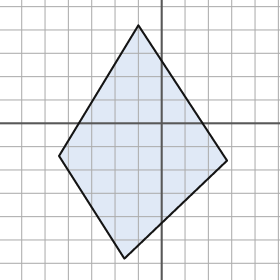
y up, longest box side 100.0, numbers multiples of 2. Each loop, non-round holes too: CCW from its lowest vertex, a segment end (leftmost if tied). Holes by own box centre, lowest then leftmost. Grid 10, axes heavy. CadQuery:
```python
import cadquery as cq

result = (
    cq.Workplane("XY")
    .moveTo(-16.0, -58.0)
    .lineTo(28.0, -16.0)
    .lineTo(-10.0, 42.0)
    .lineTo(-44.0, -14.0)
    .close()
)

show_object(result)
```